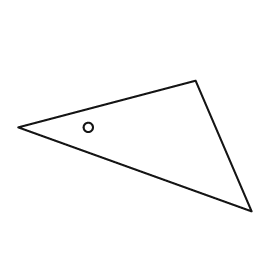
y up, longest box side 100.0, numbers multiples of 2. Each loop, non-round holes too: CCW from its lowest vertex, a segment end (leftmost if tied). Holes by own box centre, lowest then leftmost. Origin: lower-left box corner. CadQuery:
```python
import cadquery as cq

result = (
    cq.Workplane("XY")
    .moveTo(100.0, 0.0)
    .lineTo(76.0, 56.0)
    .lineTo(0.0, 36.0)
    .close()
    .moveTo(30.0, 36.0)
    .circle(2.0)
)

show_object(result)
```